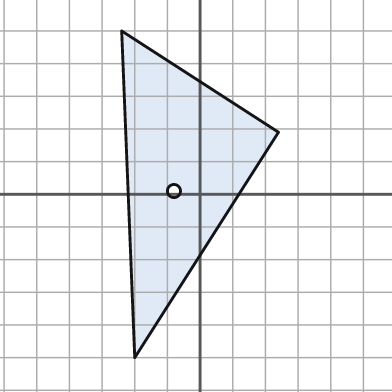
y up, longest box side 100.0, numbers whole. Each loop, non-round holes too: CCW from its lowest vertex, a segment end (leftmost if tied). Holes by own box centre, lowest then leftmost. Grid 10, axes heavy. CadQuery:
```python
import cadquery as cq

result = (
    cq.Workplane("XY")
    .moveTo(-20.0, -50.0)
    .lineTo(24.0, 19.0)
    .lineTo(-24.0, 50.0)
    .close()
    .moveTo(-8.0, 1.0)
    .circle(2.0)
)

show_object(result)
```